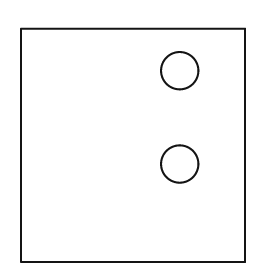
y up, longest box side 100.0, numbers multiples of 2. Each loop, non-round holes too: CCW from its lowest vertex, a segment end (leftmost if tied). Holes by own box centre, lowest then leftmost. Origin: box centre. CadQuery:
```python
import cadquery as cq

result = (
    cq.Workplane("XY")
    .moveTo(-48.0, -50.0)
    .lineTo(48.0, -50.0)
    .lineTo(48.0, 50.0)
    .lineTo(-48.0, 50.0)
    .close()
    .moveTo(20.0, -8.0)
    .circle(8.0)
    .moveTo(20.0, 32.0)
    .circle(8.0)
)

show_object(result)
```